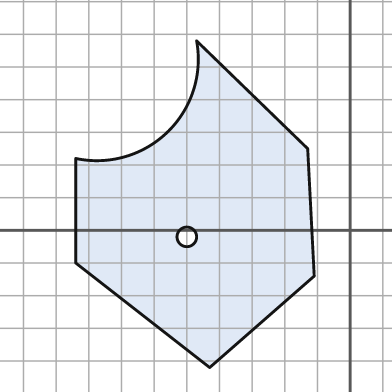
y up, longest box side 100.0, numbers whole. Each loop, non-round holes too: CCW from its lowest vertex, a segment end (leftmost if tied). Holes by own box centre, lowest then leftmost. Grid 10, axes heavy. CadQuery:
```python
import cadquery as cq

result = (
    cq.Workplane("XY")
    .moveTo(-43.0, -42.0)
    .lineTo(-11.0, -14.0)
    .lineTo(-13.0, 25.0)
    .lineTo(-47.0, 58.0)
    .threePointArc((-56.0, 30.0), (-84.0, 22.0))
    .lineTo(-84.0, -10.0)
    .close()
    .moveTo(-50.0, -2.0)
    .circle(3.0)
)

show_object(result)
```